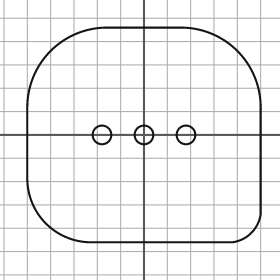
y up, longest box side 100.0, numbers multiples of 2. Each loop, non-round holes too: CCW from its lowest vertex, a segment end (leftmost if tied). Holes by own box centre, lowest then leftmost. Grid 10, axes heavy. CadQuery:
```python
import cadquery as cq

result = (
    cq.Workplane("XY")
    .moveTo(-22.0, -46.0)
    .lineTo(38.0, -46.0)
    .threePointArc((46.0, -42.0), (50.0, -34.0))
    .lineTo(50.0, 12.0)
    .threePointArc((40.0, 36.0), (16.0, 46.0))
    .lineTo(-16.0, 46.0)
    .threePointArc((-40.0, 36.0), (-50.0, 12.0))
    .lineTo(-50.0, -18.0)
    .threePointArc((-42.0, -38.0), (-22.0, -46.0))
    .close()
    .moveTo(-18.0, 0.0)
    .circle(4.0)
    .moveTo(0.0, 0.0)
    .circle(4.0)
    .moveTo(18.0, 0.0)
    .circle(4.0)
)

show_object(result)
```